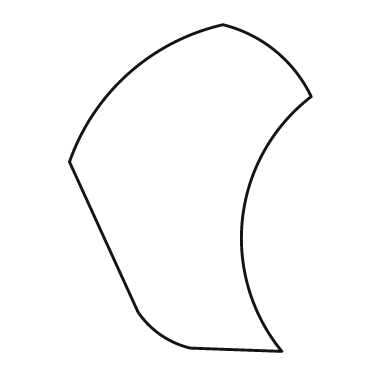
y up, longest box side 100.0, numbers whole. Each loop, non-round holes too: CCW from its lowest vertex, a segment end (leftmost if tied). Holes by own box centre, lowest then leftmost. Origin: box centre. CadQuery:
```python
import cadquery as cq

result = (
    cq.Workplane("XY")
    .moveTo(28.0, -50.0)
    .threePointArc((16.0, -9.0), (37.0, 28.0))
    .threePointArc((26.0, 42.0), (10.0, 50.0))
    .threePointArc((-19.0, 35.0), (-37.0, 8.0))
    .lineTo(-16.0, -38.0)
    .threePointArc((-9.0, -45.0), (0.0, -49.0))
    .close()
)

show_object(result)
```